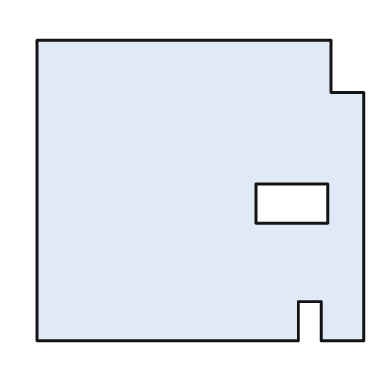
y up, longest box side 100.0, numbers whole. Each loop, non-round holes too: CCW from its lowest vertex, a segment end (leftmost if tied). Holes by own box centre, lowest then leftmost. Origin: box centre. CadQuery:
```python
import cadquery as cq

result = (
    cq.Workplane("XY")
    .moveTo(-50.0, -46.0)
    .lineTo(30.0, -46.0)
    .lineTo(30.0, -34.0)
    .lineTo(37.0, -34.0)
    .lineTo(37.0, -46.0)
    .lineTo(50.0, -46.0)
    .lineTo(50.0, 30.0)
    .lineTo(40.0, 30.0)
    .lineTo(40.0, 46.0)
    .lineTo(-50.0, 46.0)
    .close()
    .moveTo(17.0, -10.0)
    .lineTo(39.0, -10.0)
    .lineTo(39.0, 2.0)
    .lineTo(17.0, 2.0)
    .close()
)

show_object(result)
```